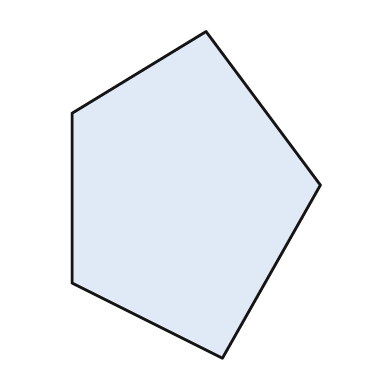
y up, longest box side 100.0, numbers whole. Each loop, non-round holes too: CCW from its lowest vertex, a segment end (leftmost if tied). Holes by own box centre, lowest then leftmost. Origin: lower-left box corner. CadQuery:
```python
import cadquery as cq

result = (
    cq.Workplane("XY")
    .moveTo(46.0, 0.0)
    .lineTo(76.0, 53.0)
    .lineTo(41.0, 100.0)
    .lineTo(0.0, 75.0)
    .lineTo(0.0, 23.0)
    .close()
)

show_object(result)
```